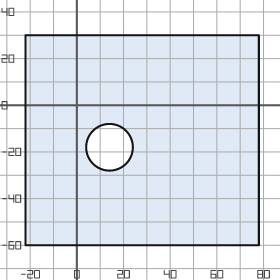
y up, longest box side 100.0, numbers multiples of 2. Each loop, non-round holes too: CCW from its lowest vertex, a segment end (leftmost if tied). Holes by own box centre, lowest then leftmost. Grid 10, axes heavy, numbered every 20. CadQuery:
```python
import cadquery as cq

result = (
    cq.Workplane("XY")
    .moveTo(-22.0, -60.0)
    .lineTo(78.0, -60.0)
    .lineTo(78.0, 30.0)
    .lineTo(-22.0, 30.0)
    .close()
    .moveTo(14.0, -18.0)
    .circle(10.0)
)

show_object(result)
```